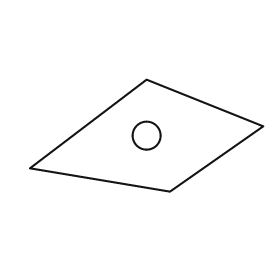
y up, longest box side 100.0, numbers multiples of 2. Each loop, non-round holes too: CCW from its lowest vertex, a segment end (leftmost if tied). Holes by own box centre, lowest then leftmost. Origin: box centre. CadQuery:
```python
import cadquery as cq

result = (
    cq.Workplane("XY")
    .moveTo(10.0, -24.0)
    .lineTo(50.0, 4.0)
    .lineTo(0.0, 24.0)
    .lineTo(-50.0, -14.0)
    .close()
    .moveTo(0.0, 0.0)
    .circle(6.0)
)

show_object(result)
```